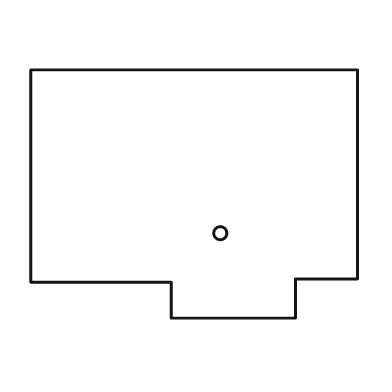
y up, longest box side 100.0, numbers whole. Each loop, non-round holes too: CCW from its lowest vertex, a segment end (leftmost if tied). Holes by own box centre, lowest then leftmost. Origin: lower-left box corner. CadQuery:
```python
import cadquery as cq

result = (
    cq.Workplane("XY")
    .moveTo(43.0, 0.0)
    .lineTo(81.0, 0.0)
    .lineTo(81.0, 12.0)
    .lineTo(100.0, 12.0)
    .lineTo(100.0, 76.0)
    .lineTo(0.0, 76.0)
    .lineTo(0.0, 11.0)
    .lineTo(43.0, 11.0)
    .close()
    .moveTo(58.0, 26.0)
    .circle(2.0)
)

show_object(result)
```